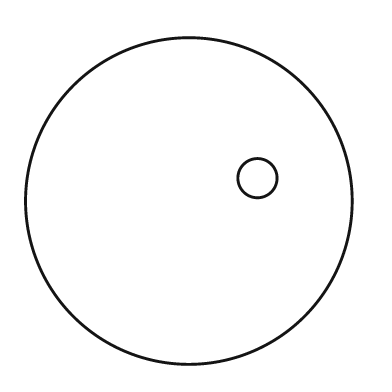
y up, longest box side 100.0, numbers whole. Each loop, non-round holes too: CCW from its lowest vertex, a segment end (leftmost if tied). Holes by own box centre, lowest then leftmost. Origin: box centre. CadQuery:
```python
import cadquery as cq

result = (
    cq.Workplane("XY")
    .moveTo(0.0, 0.0)
    .circle(50.0)
    .moveTo(21.0, 7.0)
    .circle(6.0)
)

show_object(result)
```